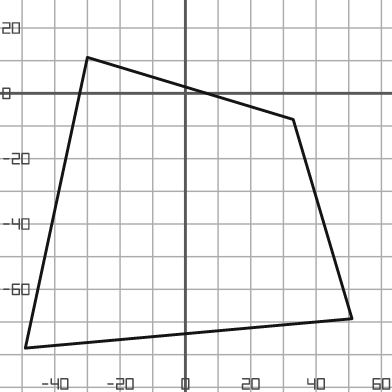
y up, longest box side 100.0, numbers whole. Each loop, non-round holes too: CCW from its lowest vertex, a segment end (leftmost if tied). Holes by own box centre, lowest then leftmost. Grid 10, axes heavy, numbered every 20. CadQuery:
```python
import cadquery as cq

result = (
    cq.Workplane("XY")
    .moveTo(-49.0, -78.0)
    .lineTo(51.0, -69.0)
    .lineTo(33.0, -8.0)
    .lineTo(-30.0, 11.0)
    .close()
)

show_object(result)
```